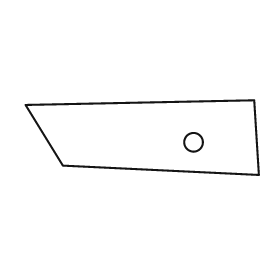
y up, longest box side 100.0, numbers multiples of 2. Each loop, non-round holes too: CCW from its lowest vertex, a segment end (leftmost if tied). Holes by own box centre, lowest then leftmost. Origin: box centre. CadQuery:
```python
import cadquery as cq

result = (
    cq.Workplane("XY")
    .moveTo(50.0, -16.0)
    .lineTo(48.0, 16.0)
    .lineTo(-50.0, 14.0)
    .lineTo(-34.0, -12.0)
    .close()
    .moveTo(22.0, -2.0)
    .circle(4.0)
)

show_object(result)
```